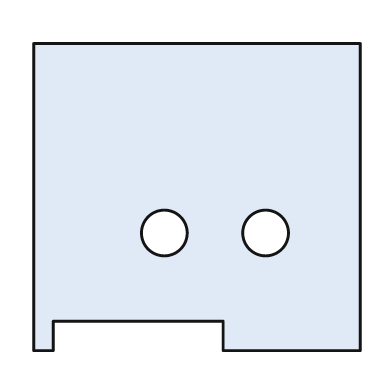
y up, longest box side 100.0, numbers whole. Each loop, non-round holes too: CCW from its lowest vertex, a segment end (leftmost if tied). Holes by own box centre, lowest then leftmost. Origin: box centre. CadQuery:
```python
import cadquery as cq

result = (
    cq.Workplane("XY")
    .moveTo(-50.0, -47.0)
    .lineTo(-44.0, -47.0)
    .lineTo(-44.0, -38.0)
    .lineTo(8.0, -38.0)
    .lineTo(8.0, -47.0)
    .lineTo(50.0, -47.0)
    .lineTo(50.0, 47.0)
    .lineTo(-50.0, 47.0)
    .close()
    .moveTo(-10.0, -11.0)
    .circle(7.0)
    .moveTo(21.0, -11.0)
    .circle(7.0)
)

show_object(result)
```